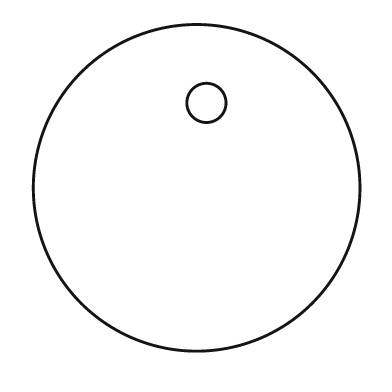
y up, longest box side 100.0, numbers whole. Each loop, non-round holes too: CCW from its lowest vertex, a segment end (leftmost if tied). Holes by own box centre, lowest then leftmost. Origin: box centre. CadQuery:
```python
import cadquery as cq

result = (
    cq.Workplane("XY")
    .moveTo(0.0, 0.0)
    .circle(50.0)
    .moveTo(3.0, 26.0)
    .circle(6.0)
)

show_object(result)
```